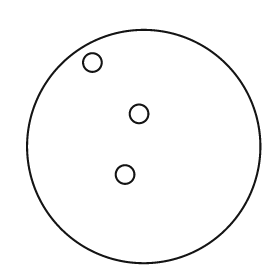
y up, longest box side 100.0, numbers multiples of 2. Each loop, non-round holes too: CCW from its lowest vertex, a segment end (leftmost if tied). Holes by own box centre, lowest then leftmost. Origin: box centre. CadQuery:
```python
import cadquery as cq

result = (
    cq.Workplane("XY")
    .moveTo(0.0, 0.0)
    .circle(50.0)
    .moveTo(-8.0, -12.0)
    .circle(4.0)
    .moveTo(-2.0, 14.0)
    .circle(4.0)
    .moveTo(-22.0, 36.0)
    .circle(4.0)
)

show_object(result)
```